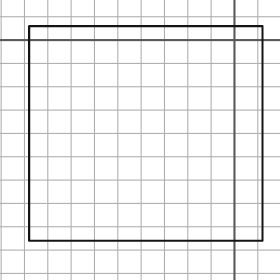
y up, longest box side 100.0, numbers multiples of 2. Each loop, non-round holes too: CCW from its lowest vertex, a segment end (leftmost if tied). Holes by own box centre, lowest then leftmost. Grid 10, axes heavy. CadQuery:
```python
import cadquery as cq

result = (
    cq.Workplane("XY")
    .moveTo(-88.0, -86.0)
    .lineTo(12.0, -86.0)
    .lineTo(12.0, 6.0)
    .lineTo(-88.0, 6.0)
    .close()
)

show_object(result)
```